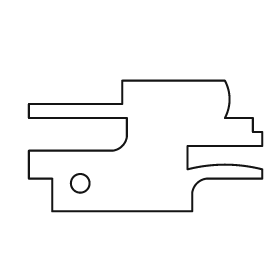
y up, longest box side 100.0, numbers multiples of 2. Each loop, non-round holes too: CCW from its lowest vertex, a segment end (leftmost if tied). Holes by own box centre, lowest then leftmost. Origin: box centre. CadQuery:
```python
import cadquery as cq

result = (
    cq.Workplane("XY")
    .moveTo(-40.0, -28.0)
    .lineTo(20.0, -28.0)
    .lineTo(20.0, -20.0)
    .threePointArc((22.0, -16.0), (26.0, -14.0))
    .lineTo(50.0, -14.0)
    .lineTo(50.0, -10.0)
    .threePointArc((34.0, -8.0), (18.0, -10.0))
    .lineTo(18.0, 0.0)
    .lineTo(50.0, 0.0)
    .lineTo(50.0, 6.0)
    .lineTo(46.0, 6.0)
    .lineTo(46.0, 12.0)
    .lineTo(34.0, 12.0)
    .threePointArc((36.0, 20.0), (34.0, 28.0))
    .lineTo(-10.0, 28.0)
    .lineTo(-10.0, 18.0)
    .lineTo(-50.0, 18.0)
    .lineTo(-50.0, 12.0)
    .lineTo(-8.0, 12.0)
    .lineTo(-8.0, 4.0)
    .threePointArc((-10.0, 0.0), (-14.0, -2.0))
    .lineTo(-50.0, -2.0)
    .lineTo(-50.0, -14.0)
    .lineTo(-40.0, -14.0)
    .close()
    .moveTo(-28.0, -16.0)
    .circle(4.0)
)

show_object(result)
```